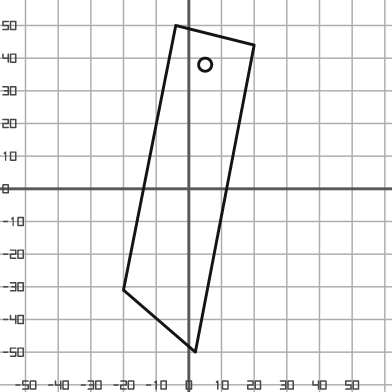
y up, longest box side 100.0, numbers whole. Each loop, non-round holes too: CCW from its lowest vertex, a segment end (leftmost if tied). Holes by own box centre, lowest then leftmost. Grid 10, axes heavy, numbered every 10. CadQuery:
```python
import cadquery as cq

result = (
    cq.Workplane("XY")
    .moveTo(2.0, -50.0)
    .lineTo(20.0, 44.0)
    .lineTo(-4.0, 50.0)
    .lineTo(-20.0, -31.0)
    .close()
    .moveTo(5.0, 38.0)
    .circle(2.0)
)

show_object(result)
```